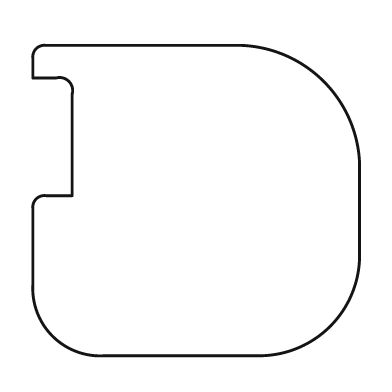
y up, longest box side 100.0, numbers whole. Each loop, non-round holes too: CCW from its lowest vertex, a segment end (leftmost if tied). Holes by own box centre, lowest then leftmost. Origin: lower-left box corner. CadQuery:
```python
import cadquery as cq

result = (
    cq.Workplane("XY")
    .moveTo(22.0, 0.0)
    .lineTo(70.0, 0.0)
    .threePointArc((91.0, 9.0), (100.0, 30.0))
    .lineTo(100.0, 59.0)
    .threePointArc((89.0, 84.0), (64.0, 95.0))
    .lineTo(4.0, 95.0)
    .threePointArc((1.0, 94.0), (0.0, 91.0))
    .lineTo(0.0, 85.0)
    .lineTo(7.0, 85.0)
    .threePointArc((11.0, 84.0), (12.0, 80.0))
    .lineTo(12.0, 49.0)
    .lineTo(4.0, 49.0)
    .threePointArc((1.0, 48.0), (0.0, 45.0))
    .lineTo(0.0, 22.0)
    .threePointArc((6.0, 6.0), (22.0, 0.0))
    .close()
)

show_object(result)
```